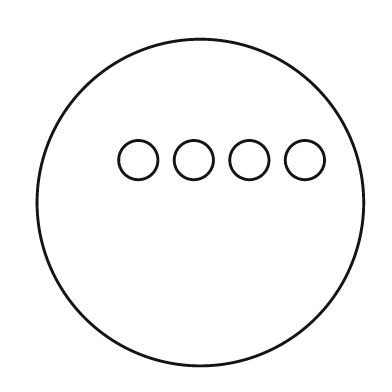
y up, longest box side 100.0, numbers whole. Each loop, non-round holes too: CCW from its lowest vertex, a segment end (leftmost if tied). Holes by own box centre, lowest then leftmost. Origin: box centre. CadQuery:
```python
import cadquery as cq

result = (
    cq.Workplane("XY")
    .moveTo(0.0, 0.0)
    .circle(50.0)
    .moveTo(-19.0, 13.0)
    .circle(6.0)
    .moveTo(-2.0, 13.0)
    .circle(6.0)
    .moveTo(15.0, 13.0)
    .circle(6.0)
    .moveTo(32.0, 13.0)
    .circle(6.0)
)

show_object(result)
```